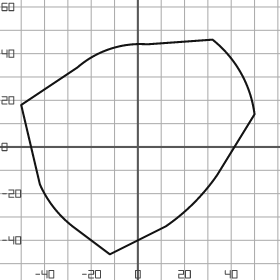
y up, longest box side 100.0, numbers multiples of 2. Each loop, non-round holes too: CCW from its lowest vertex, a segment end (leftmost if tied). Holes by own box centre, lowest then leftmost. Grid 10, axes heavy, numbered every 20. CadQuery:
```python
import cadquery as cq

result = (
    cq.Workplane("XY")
    .moveTo(-12.0, -46.0)
    .lineTo(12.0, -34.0)
    .threePointArc((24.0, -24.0), (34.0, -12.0))
    .lineTo(50.0, 14.0)
    .threePointArc((44.0, 32.0), (32.0, 46.0))
    .lineTo(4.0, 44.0)
    .threePointArc((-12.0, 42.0), (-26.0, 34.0))
    .lineTo(-50.0, 18.0)
    .lineTo(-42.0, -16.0)
    .threePointArc((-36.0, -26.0), (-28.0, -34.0))
    .close()
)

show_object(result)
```